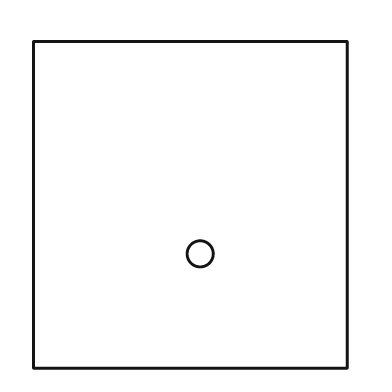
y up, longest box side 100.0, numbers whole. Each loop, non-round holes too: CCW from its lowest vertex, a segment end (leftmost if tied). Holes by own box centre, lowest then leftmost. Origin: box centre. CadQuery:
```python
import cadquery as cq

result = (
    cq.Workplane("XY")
    .moveTo(-48.0, -50.0)
    .lineTo(48.0, -50.0)
    .lineTo(48.0, 50.0)
    .lineTo(-48.0, 50.0)
    .close()
    .moveTo(3.0, -15.0)
    .circle(4.0)
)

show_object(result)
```